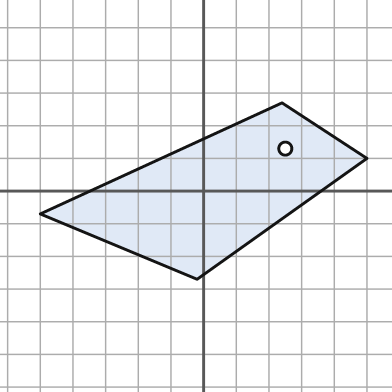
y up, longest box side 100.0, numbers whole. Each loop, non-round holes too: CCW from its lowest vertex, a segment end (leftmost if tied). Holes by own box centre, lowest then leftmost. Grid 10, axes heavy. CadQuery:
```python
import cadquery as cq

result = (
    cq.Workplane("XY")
    .moveTo(-2.0, -27.0)
    .lineTo(50.0, 10.0)
    .lineTo(24.0, 27.0)
    .lineTo(-50.0, -7.0)
    .close()
    .moveTo(25.0, 13.0)
    .circle(2.0)
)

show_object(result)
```